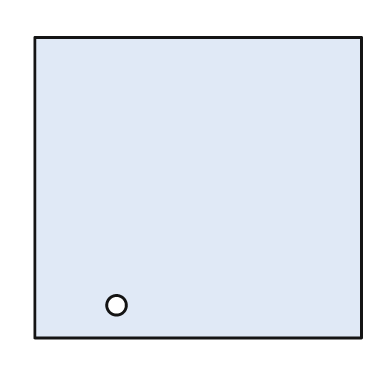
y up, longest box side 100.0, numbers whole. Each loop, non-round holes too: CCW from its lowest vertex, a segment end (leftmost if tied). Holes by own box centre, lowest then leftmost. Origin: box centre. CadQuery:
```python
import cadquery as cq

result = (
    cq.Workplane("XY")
    .moveTo(-50.0, -46.0)
    .lineTo(50.0, -46.0)
    .lineTo(50.0, 46.0)
    .lineTo(-50.0, 46.0)
    .close()
    .moveTo(-25.0, -36.0)
    .circle(3.0)
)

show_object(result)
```